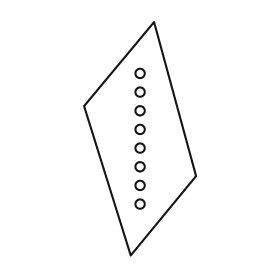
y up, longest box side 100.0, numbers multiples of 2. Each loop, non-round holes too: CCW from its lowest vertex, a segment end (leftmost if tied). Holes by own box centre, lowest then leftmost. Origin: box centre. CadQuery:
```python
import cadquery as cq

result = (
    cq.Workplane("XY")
    .moveTo(-4.0, -50.0)
    .lineTo(24.0, -16.0)
    .lineTo(6.0, 50.0)
    .lineTo(-24.0, 14.0)
    .close()
    .moveTo(0.0, -28.0)
    .circle(2.0)
    .moveTo(0.0, -20.0)
    .circle(2.0)
    .moveTo(0.0, -12.0)
    .circle(2.0)
    .moveTo(0.0, -4.0)
    .circle(2.0)
    .moveTo(0.0, 4.0)
    .circle(2.0)
    .moveTo(0.0, 12.0)
    .circle(2.0)
    .moveTo(0.0, 20.0)
    .circle(2.0)
    .moveTo(0.0, 28.0)
    .circle(2.0)
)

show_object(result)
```